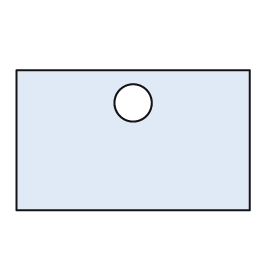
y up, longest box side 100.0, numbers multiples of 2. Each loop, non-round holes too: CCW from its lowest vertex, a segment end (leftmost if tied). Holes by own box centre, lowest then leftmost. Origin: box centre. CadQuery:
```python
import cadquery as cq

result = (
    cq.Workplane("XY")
    .moveTo(-50.0, -30.0)
    .lineTo(50.0, -30.0)
    .lineTo(50.0, 30.0)
    .lineTo(-50.0, 30.0)
    .close()
    .moveTo(0.0, 16.0)
    .circle(8.0)
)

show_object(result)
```